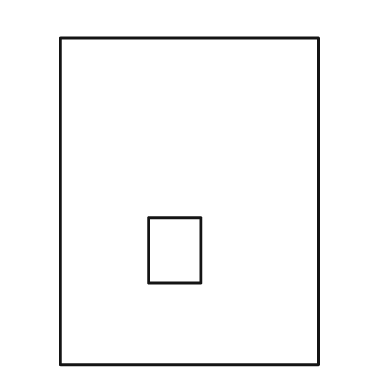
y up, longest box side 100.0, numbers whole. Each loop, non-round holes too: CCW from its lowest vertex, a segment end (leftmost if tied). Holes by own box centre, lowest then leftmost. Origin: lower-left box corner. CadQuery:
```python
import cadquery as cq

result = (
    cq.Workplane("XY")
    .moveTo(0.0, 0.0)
    .lineTo(79.0, 0.0)
    .lineTo(79.0, 100.0)
    .lineTo(0.0, 100.0)
    .close()
    .moveTo(27.0, 25.0)
    .lineTo(43.0, 25.0)
    .lineTo(43.0, 45.0)
    .lineTo(27.0, 45.0)
    .close()
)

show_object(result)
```